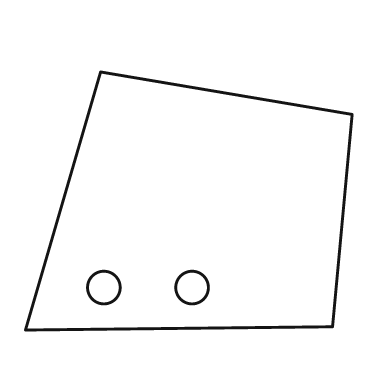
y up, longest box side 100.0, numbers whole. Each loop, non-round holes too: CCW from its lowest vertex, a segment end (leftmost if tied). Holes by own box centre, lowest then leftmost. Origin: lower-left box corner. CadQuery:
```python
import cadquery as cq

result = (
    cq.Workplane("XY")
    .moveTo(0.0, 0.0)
    .lineTo(94.0, 1.0)
    .lineTo(100.0, 66.0)
    .lineTo(23.0, 79.0)
    .close()
    .moveTo(24.0, 13.0)
    .circle(5.0)
    .moveTo(51.0, 13.0)
    .circle(5.0)
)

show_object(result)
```